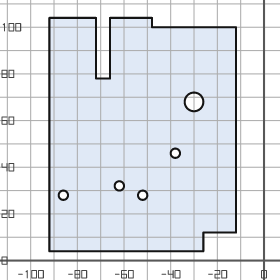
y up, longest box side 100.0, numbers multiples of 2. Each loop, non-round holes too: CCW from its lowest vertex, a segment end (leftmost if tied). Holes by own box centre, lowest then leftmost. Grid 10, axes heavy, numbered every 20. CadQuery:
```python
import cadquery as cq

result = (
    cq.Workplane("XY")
    .moveTo(-92.0, 4.0)
    .lineTo(-26.0, 4.0)
    .lineTo(-26.0, 12.0)
    .lineTo(-12.0, 12.0)
    .lineTo(-12.0, 100.0)
    .lineTo(-48.0, 100.0)
    .lineTo(-48.0, 104.0)
    .lineTo(-66.0, 104.0)
    .lineTo(-66.0, 78.0)
    .lineTo(-72.0, 78.0)
    .lineTo(-72.0, 104.0)
    .lineTo(-92.0, 104.0)
    .close()
    .moveTo(-86.0, 28.0)
    .circle(2.0)
    .moveTo(-52.0, 28.0)
    .circle(2.0)
    .moveTo(-62.0, 32.0)
    .circle(2.0)
    .moveTo(-38.0, 46.0)
    .circle(2.0)
    .moveTo(-30.0, 68.0)
    .circle(4.0)
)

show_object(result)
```